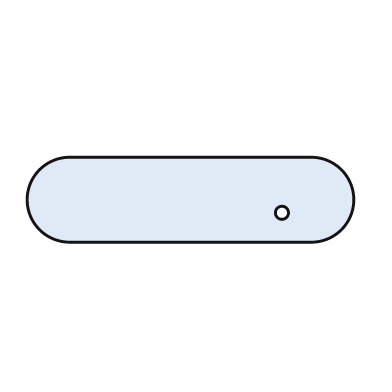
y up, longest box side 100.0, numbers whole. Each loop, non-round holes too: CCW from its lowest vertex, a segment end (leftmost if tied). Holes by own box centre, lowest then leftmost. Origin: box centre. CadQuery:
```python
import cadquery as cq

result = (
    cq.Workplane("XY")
    .moveTo(-37.0, -13.0)
    .lineTo(37.0, -13.0)
    .threePointArc((50.0, 0.0), (37.0, 13.0))
    .lineTo(-37.0, 13.0)
    .threePointArc((-50.0, 0.0), (-37.0, -13.0))
    .close()
    .moveTo(28.0, -4.0)
    .circle(2.0)
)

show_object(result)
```